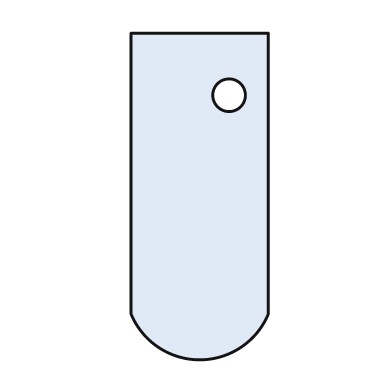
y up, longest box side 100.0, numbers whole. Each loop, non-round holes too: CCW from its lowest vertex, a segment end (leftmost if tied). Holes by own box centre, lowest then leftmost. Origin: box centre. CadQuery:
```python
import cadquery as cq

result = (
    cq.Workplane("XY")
    .moveTo(-21.0, -36.0)
    .threePointArc((0.0, -50.0), (21.0, -36.0))
    .lineTo(21.0, 50.0)
    .lineTo(-21.0, 50.0)
    .close()
    .moveTo(9.0, 31.0)
    .circle(5.0)
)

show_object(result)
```